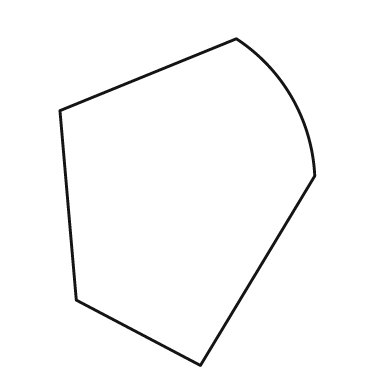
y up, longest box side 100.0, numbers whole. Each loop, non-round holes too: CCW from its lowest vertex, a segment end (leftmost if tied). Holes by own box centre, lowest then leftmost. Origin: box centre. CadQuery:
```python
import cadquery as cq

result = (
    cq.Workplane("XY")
    .moveTo(4.0, -50.0)
    .lineTo(39.0, 8.0)
    .threePointArc((32.0, 32.0), (15.0, 50.0))
    .lineTo(-39.0, 28.0)
    .lineTo(-34.0, -30.0)
    .close()
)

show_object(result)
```